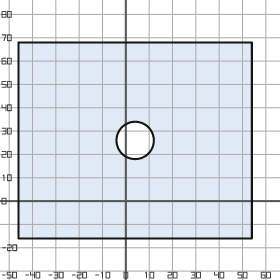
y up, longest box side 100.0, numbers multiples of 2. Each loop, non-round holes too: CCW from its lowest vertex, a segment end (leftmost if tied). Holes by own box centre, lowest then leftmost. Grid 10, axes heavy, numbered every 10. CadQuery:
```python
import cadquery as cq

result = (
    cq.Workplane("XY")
    .moveTo(-46.0, -16.0)
    .lineTo(54.0, -16.0)
    .lineTo(54.0, 68.0)
    .lineTo(-46.0, 68.0)
    .close()
    .moveTo(4.0, 26.0)
    .circle(8.0)
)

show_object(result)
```